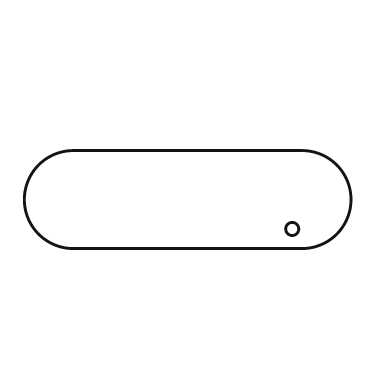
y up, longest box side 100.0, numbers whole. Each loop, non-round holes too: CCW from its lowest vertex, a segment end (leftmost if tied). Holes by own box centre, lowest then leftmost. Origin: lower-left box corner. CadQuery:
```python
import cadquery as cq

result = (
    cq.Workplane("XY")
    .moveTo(15.0, 0.0)
    .lineTo(85.0, 0.0)
    .threePointArc((100.0, 15.0), (85.0, 30.0))
    .lineTo(15.0, 30.0)
    .threePointArc((0.0, 15.0), (15.0, 0.0))
    .close()
    .moveTo(82.0, 6.0)
    .circle(2.0)
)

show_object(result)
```